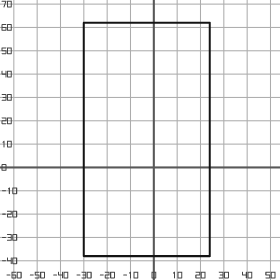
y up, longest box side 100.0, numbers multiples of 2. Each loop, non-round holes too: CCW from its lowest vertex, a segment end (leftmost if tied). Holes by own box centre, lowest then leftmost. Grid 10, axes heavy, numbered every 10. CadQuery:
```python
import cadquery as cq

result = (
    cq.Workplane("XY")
    .moveTo(-30.0, -38.0)
    .lineTo(24.0, -38.0)
    .lineTo(24.0, 62.0)
    .lineTo(-30.0, 62.0)
    .close()
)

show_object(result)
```